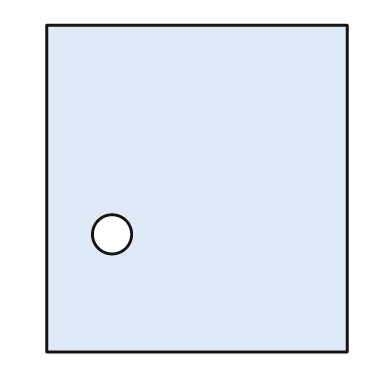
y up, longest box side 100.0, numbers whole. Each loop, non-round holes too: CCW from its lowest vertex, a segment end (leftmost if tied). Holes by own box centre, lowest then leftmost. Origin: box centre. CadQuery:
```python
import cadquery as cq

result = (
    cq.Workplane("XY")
    .moveTo(-46.0, -50.0)
    .lineTo(46.0, -50.0)
    .lineTo(46.0, 50.0)
    .lineTo(-46.0, 50.0)
    .close()
    .moveTo(-26.0, -14.0)
    .circle(6.0)
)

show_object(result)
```